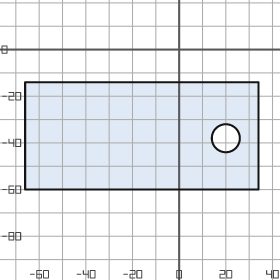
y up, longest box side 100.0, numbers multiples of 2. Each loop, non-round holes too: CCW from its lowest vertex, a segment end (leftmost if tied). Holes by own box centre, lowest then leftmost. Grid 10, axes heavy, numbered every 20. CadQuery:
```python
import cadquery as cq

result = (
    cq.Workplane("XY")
    .moveTo(-66.0, -60.0)
    .lineTo(34.0, -60.0)
    .lineTo(34.0, -14.0)
    .lineTo(-66.0, -14.0)
    .close()
    .moveTo(20.0, -38.0)
    .circle(6.0)
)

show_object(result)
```